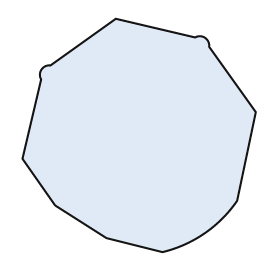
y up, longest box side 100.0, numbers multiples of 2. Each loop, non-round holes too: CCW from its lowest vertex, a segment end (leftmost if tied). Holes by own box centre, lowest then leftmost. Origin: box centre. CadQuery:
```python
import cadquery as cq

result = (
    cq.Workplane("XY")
    .moveTo(10.0, -50.0)
    .threePointArc((28.0, -42.0), (42.0, -28.0))
    .lineTo(50.0, 10.0)
    .lineTo(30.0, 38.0)
    .threePointArc((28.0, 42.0), (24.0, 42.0))
    .lineTo(-10.0, 50.0)
    .lineTo(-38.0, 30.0)
    .threePointArc((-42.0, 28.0), (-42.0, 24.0))
    .lineTo(-50.0, -10.0)
    .lineTo(-36.0, -30.0)
    .lineTo(-14.0, -44.0)
    .close()
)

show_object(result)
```